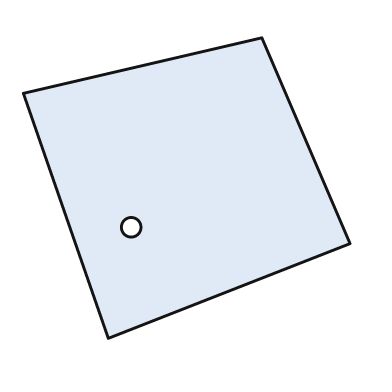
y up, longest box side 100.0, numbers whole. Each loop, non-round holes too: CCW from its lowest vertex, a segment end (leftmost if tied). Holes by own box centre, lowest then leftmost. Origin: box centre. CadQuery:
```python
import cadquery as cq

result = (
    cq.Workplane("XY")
    .moveTo(-24.0, -46.0)
    .lineTo(50.0, -17.0)
    .lineTo(23.0, 46.0)
    .lineTo(-50.0, 29.0)
    .close()
    .moveTo(-17.0, -12.0)
    .circle(3.0)
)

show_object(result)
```